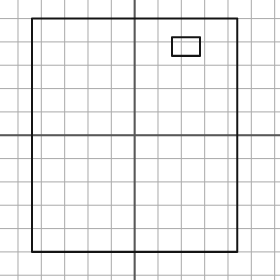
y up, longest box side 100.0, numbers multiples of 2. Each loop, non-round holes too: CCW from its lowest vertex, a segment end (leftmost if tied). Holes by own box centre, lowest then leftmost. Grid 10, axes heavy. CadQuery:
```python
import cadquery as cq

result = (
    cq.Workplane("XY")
    .moveTo(-44.0, -50.0)
    .lineTo(44.0, -50.0)
    .lineTo(44.0, 50.0)
    .lineTo(-44.0, 50.0)
    .close()
    .moveTo(16.0, 34.0)
    .lineTo(28.0, 34.0)
    .lineTo(28.0, 42.0)
    .lineTo(16.0, 42.0)
    .close()
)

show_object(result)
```